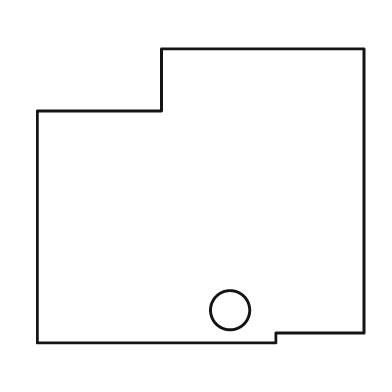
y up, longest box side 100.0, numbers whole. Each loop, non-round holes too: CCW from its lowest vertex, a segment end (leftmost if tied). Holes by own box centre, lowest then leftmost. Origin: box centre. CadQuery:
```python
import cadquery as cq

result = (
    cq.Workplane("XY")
    .moveTo(-50.0, -45.0)
    .lineTo(23.0, -45.0)
    .lineTo(23.0, -42.0)
    .lineTo(50.0, -42.0)
    .lineTo(50.0, 45.0)
    .lineTo(-12.0, 45.0)
    .lineTo(-12.0, 26.0)
    .lineTo(-50.0, 26.0)
    .close()
    .moveTo(9.0, -35.0)
    .circle(6.0)
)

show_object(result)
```